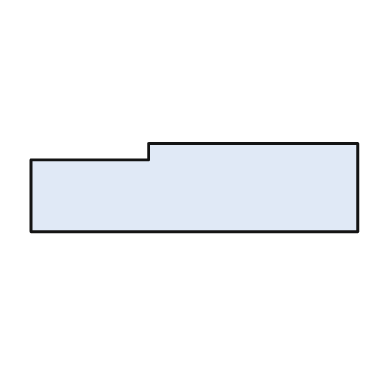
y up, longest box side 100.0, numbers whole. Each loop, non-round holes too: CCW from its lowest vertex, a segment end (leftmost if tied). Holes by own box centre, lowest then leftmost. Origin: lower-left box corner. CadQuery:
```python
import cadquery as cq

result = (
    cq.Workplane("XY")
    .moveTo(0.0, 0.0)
    .lineTo(100.0, 0.0)
    .lineTo(100.0, 27.0)
    .lineTo(36.0, 27.0)
    .lineTo(36.0, 22.0)
    .lineTo(0.0, 22.0)
    .close()
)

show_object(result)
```